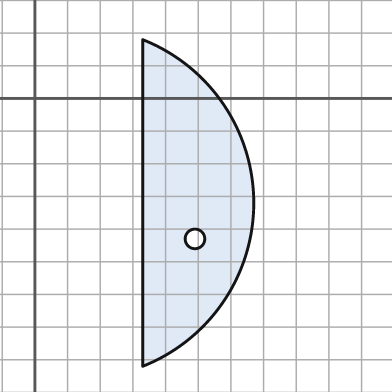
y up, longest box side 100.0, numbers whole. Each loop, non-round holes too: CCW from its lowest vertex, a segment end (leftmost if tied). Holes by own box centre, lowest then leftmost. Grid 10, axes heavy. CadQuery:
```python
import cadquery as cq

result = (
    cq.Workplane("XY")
    .moveTo(33.0, -82.0)
    .threePointArc((67.0, -32.0), (33.0, 18.0))
    .close()
    .moveTo(49.0, -43.0)
    .circle(3.0)
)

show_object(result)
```